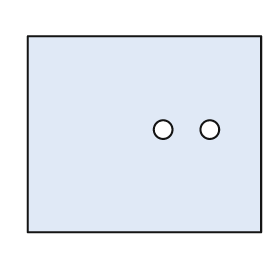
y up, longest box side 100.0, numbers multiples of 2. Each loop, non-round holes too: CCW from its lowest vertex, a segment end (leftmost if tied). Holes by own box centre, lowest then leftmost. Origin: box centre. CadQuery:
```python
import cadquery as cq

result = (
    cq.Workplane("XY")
    .moveTo(-50.0, -42.0)
    .lineTo(50.0, -42.0)
    .lineTo(50.0, 42.0)
    .lineTo(-50.0, 42.0)
    .close()
    .moveTo(8.0, 2.0)
    .circle(4.0)
    .moveTo(28.0, 2.0)
    .circle(4.0)
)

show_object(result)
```